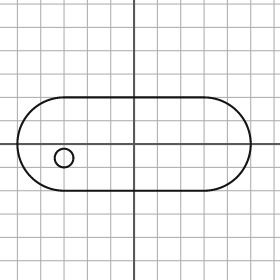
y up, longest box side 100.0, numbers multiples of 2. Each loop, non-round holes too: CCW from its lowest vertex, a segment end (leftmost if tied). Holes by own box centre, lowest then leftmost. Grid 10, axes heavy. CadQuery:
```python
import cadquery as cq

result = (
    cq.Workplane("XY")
    .moveTo(-30.0, -20.0)
    .lineTo(30.0, -20.0)
    .threePointArc((50.0, 0.0), (30.0, 20.0))
    .lineTo(-30.0, 20.0)
    .threePointArc((-50.0, 0.0), (-30.0, -20.0))
    .close()
    .moveTo(-30.0, -6.0)
    .circle(4.0)
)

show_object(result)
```